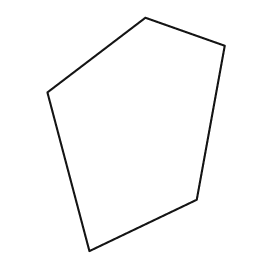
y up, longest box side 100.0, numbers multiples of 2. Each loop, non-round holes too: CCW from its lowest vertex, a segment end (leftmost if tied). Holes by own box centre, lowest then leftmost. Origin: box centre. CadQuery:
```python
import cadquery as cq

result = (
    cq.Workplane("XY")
    .moveTo(-20.0, -50.0)
    .lineTo(26.0, -28.0)
    .lineTo(38.0, 38.0)
    .lineTo(4.0, 50.0)
    .lineTo(-38.0, 18.0)
    .close()
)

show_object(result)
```